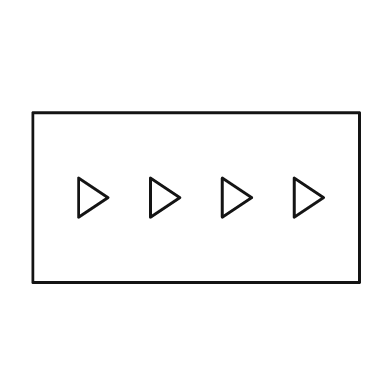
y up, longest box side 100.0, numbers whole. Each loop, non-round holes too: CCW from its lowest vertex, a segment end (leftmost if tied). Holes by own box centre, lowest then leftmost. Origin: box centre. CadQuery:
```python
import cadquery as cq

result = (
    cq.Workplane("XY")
    .moveTo(-50.0, -26.0)
    .lineTo(50.0, -26.0)
    .lineTo(50.0, 26.0)
    .lineTo(-50.0, 26.0)
    .close()
    .moveTo(-36.0, -6.0)
    .lineTo(-27.0, 0.0)
    .lineTo(-36.0, 6.0)
    .close()
    .moveTo(-14.0, -6.0)
    .lineTo(-5.0, 0.0)
    .lineTo(-14.0, 6.0)
    .close()
    .moveTo(8.0, -6.0)
    .lineTo(17.0, 0.0)
    .lineTo(8.0, 6.0)
    .close()
    .moveTo(30.0, -6.0)
    .lineTo(39.0, 0.0)
    .lineTo(30.0, 6.0)
    .close()
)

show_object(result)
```